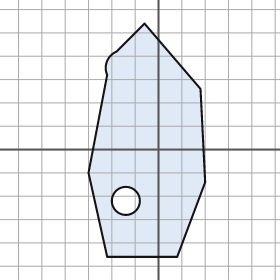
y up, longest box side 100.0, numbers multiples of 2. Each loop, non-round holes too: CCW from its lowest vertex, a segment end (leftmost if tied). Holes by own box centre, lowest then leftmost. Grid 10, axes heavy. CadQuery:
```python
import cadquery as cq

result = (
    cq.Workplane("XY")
    .moveTo(-22.0, -46.0)
    .lineTo(8.0, -46.0)
    .lineTo(20.0, -14.0)
    .lineTo(18.0, 26.0)
    .lineTo(-6.0, 54.0)
    .lineTo(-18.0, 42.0)
    .threePointArc((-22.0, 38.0), (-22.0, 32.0))
    .lineTo(-30.0, -10.0)
    .close()
    .moveTo(-14.0, -22.0)
    .circle(6.0)
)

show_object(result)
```